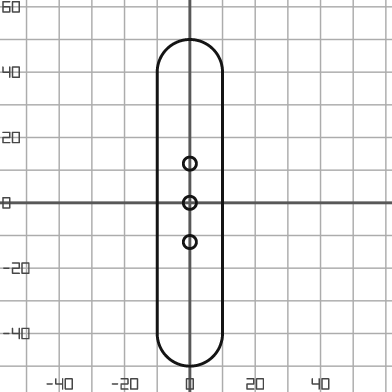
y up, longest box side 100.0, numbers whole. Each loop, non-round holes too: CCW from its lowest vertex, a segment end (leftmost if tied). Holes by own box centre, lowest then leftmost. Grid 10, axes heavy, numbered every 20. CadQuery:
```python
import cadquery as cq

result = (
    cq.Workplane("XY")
    .moveTo(-10.0, -40.0)
    .threePointArc((0.0, -50.0), (10.0, -40.0))
    .lineTo(10.0, 40.0)
    .threePointArc((0.0, 50.0), (-10.0, 40.0))
    .close()
    .moveTo(0.0, -12.0)
    .circle(2.0)
    .moveTo(0.0, 0.0)
    .circle(2.0)
    .moveTo(0.0, 12.0)
    .circle(2.0)
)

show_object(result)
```